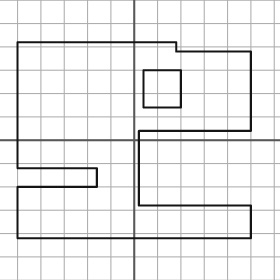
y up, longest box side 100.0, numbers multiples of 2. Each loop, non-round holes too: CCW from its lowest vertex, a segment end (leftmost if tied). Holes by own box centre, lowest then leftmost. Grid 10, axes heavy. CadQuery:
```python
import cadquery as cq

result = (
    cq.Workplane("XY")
    .moveTo(-50.0, -42.0)
    .lineTo(50.0, -42.0)
    .lineTo(50.0, -28.0)
    .lineTo(2.0, -28.0)
    .lineTo(2.0, 4.0)
    .lineTo(50.0, 4.0)
    .lineTo(50.0, 38.0)
    .lineTo(18.0, 38.0)
    .lineTo(18.0, 42.0)
    .lineTo(-50.0, 42.0)
    .lineTo(-50.0, -12.0)
    .lineTo(-16.0, -12.0)
    .lineTo(-16.0, -20.0)
    .lineTo(-50.0, -20.0)
    .close()
    .moveTo(4.0, 14.0)
    .lineTo(20.0, 14.0)
    .lineTo(20.0, 30.0)
    .lineTo(4.0, 30.0)
    .close()
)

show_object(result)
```